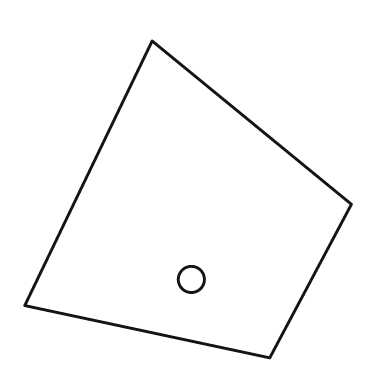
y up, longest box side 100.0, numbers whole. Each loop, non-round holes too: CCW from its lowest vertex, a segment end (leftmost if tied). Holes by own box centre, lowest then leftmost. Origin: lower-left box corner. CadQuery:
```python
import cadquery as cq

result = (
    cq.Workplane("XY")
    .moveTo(75.0, 0.0)
    .lineTo(100.0, 47.0)
    .lineTo(39.0, 97.0)
    .lineTo(0.0, 16.0)
    .close()
    .moveTo(51.0, 24.0)
    .circle(4.0)
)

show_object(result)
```